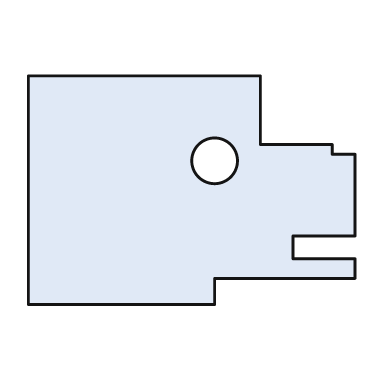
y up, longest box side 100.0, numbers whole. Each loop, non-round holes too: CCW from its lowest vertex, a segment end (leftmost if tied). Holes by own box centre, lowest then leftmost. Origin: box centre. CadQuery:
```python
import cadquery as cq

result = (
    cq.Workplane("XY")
    .moveTo(-50.0, -35.0)
    .lineTo(7.0, -35.0)
    .lineTo(7.0, -27.0)
    .lineTo(50.0, -27.0)
    .lineTo(50.0, -21.0)
    .lineTo(31.0, -21.0)
    .lineTo(31.0, -14.0)
    .lineTo(50.0, -14.0)
    .lineTo(50.0, 11.0)
    .lineTo(43.0, 11.0)
    .lineTo(43.0, 14.0)
    .lineTo(21.0, 14.0)
    .lineTo(21.0, 35.0)
    .lineTo(-50.0, 35.0)
    .close()
    .moveTo(7.0, 9.0)
    .circle(7.0)
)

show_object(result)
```